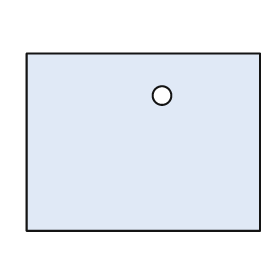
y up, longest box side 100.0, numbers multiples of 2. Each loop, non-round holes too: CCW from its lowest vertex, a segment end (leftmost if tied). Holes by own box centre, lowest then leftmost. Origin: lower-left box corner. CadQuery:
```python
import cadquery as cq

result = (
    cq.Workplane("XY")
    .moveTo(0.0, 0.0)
    .lineTo(100.0, 0.0)
    .lineTo(100.0, 76.0)
    .lineTo(0.0, 76.0)
    .close()
    .moveTo(58.0, 58.0)
    .circle(4.0)
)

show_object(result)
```